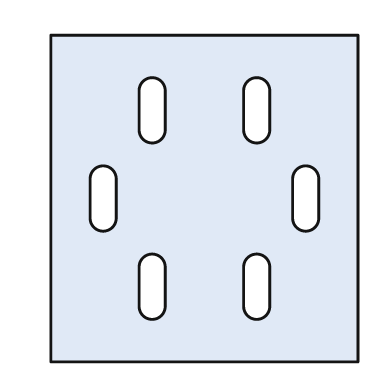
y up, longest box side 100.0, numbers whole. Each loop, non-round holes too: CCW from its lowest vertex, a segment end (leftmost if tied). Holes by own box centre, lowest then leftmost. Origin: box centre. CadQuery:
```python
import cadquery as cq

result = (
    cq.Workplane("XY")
    .moveTo(-47.0, -50.0)
    .lineTo(47.0, -50.0)
    .lineTo(47.0, 50.0)
    .lineTo(-47.0, 50.0)
    .close()
    .moveTo(-20.0, -33.0)
    .threePointArc((-16.0, -37.0), (-12.0, -33.0))
    .lineTo(-12.0, -21.0)
    .threePointArc((-16.0, -17.0), (-20.0, -21.0))
    .close()
    .moveTo(12.0, -33.0)
    .threePointArc((16.0, -37.0), (20.0, -33.0))
    .lineTo(20.0, -21.0)
    .threePointArc((16.0, -17.0), (12.0, -21.0))
    .close()
    .moveTo(-35.0, -6.0)
    .threePointArc((-31.0, -10.0), (-27.0, -6.0))
    .lineTo(-27.0, 6.0)
    .threePointArc((-31.0, 10.0), (-35.0, 6.0))
    .close()
    .moveTo(27.0, -6.0)
    .threePointArc((31.0, -10.0), (35.0, -6.0))
    .lineTo(35.0, 6.0)
    .threePointArc((31.0, 10.0), (27.0, 6.0))
    .close()
    .moveTo(-20.0, 21.0)
    .threePointArc((-16.0, 17.0), (-12.0, 21.0))
    .lineTo(-12.0, 33.0)
    .threePointArc((-16.0, 37.0), (-20.0, 33.0))
    .close()
    .moveTo(12.0, 21.0)
    .threePointArc((16.0, 17.0), (20.0, 21.0))
    .lineTo(20.0, 33.0)
    .threePointArc((16.0, 37.0), (12.0, 33.0))
    .close()
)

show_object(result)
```